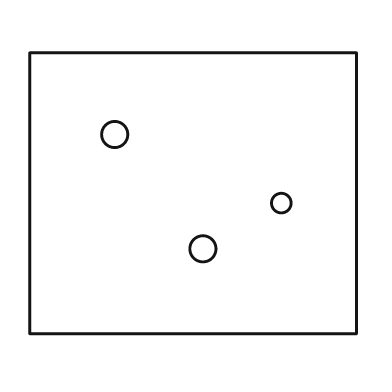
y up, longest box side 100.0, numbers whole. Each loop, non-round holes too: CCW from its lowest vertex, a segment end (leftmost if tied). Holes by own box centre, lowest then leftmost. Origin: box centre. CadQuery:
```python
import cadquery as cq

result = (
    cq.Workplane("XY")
    .moveTo(-50.0, -43.0)
    .lineTo(50.0, -43.0)
    .lineTo(50.0, 43.0)
    .lineTo(-50.0, 43.0)
    .close()
    .moveTo(3.0, -17.0)
    .circle(4.0)
    .moveTo(27.0, -3.0)
    .circle(3.0)
    .moveTo(-24.0, 18.0)
    .circle(4.0)
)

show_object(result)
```